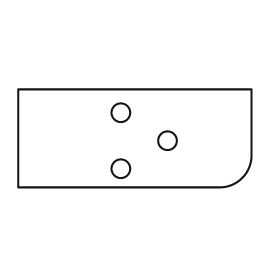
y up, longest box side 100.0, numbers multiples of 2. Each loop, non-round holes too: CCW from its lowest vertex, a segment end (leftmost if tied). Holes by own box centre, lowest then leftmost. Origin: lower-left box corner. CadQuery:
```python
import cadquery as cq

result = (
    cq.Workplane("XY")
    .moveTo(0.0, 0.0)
    .lineTo(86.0, 0.0)
    .threePointArc((96.0, 4.0), (100.0, 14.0))
    .lineTo(100.0, 42.0)
    .lineTo(0.0, 42.0)
    .close()
    .moveTo(44.0, 8.0)
    .circle(4.0)
    .moveTo(64.0, 20.0)
    .circle(4.0)
    .moveTo(44.0, 32.0)
    .circle(4.0)
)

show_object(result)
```